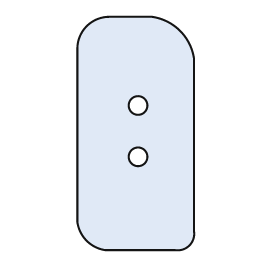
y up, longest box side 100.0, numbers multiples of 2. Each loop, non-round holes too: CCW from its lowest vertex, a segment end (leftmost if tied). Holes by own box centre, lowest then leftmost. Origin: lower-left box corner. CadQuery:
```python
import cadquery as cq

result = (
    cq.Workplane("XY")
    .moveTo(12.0, 0.0)
    .lineTo(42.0, 0.0)
    .threePointArc((48.0, 2.0), (50.0, 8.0))
    .lineTo(50.0, 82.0)
    .threePointArc((44.0, 94.0), (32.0, 100.0))
    .lineTo(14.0, 100.0)
    .threePointArc((4.0, 96.0), (0.0, 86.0))
    .lineTo(0.0, 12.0)
    .threePointArc((4.0, 4.0), (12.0, 0.0))
    .close()
    .moveTo(26.0, 40.0)
    .circle(4.0)
    .moveTo(26.0, 62.0)
    .circle(4.0)
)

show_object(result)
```